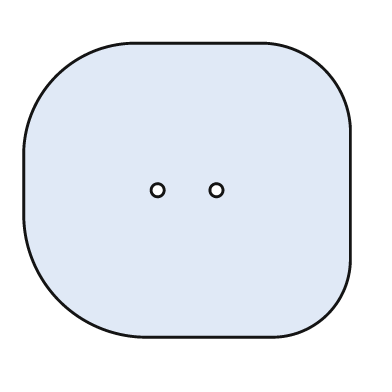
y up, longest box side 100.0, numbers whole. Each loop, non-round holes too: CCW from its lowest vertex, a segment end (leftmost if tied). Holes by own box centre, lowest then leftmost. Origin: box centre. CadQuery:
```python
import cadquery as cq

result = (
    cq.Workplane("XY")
    .moveTo(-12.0, -45.0)
    .lineTo(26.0, -45.0)
    .threePointArc((43.0, -38.0), (50.0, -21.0))
    .lineTo(50.0, 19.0)
    .threePointArc((42.0, 37.0), (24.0, 45.0))
    .lineTo(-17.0, 45.0)
    .threePointArc((-40.0, 35.0), (-50.0, 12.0))
    .lineTo(-50.0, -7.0)
    .threePointArc((-39.0, -34.0), (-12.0, -45.0))
    .close()
    .moveTo(-9.0, 0.0)
    .circle(2.0)
    .moveTo(9.0, 0.0)
    .circle(2.0)
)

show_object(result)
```